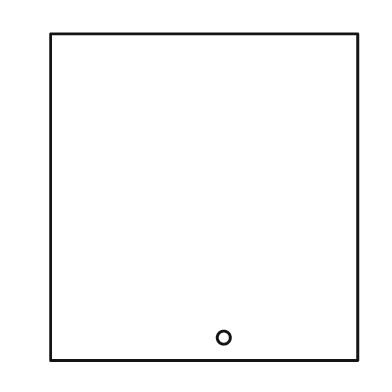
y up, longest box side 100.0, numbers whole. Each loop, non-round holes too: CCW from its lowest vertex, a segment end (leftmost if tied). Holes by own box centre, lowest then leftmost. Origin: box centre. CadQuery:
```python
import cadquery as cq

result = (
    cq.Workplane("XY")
    .moveTo(-47.0, -50.0)
    .lineTo(47.0, -50.0)
    .lineTo(47.0, 50.0)
    .lineTo(-47.0, 50.0)
    .close()
    .moveTo(6.0, -43.0)
    .circle(2.0)
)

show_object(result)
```